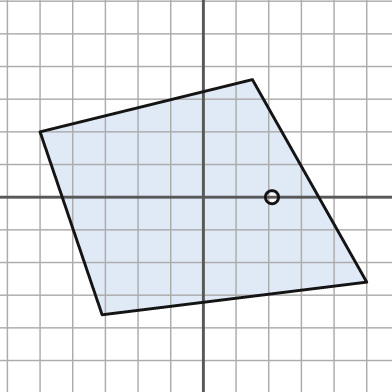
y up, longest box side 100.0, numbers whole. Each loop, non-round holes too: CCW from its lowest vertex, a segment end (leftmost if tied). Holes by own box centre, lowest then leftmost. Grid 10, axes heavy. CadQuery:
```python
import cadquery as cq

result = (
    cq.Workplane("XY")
    .moveTo(-31.0, -36.0)
    .lineTo(50.0, -26.0)
    .lineTo(15.0, 36.0)
    .lineTo(-50.0, 20.0)
    .close()
    .moveTo(21.0, 0.0)
    .circle(2.0)
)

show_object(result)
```